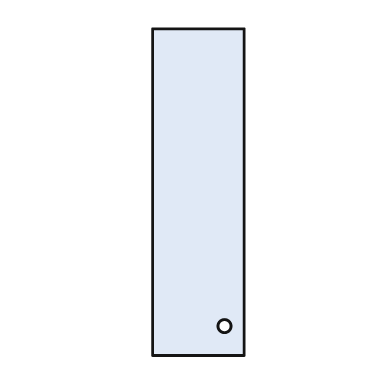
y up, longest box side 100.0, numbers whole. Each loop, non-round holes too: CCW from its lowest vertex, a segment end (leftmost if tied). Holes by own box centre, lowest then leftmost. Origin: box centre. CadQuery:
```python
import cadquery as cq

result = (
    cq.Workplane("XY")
    .moveTo(-14.0, -50.0)
    .lineTo(14.0, -50.0)
    .lineTo(14.0, 50.0)
    .lineTo(-14.0, 50.0)
    .close()
    .moveTo(8.0, -41.0)
    .circle(2.0)
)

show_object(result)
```